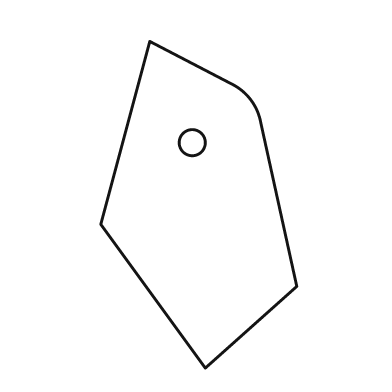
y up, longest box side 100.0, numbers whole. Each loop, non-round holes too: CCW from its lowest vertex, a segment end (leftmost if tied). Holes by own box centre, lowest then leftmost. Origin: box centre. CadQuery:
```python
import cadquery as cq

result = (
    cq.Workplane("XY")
    .moveTo(2.0, -50.0)
    .lineTo(30.0, -25.0)
    .lineTo(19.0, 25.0)
    .threePointArc((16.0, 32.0), (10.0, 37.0))
    .lineTo(-15.0, 50.0)
    .lineTo(-30.0, -6.0)
    .close()
    .moveTo(-2.0, 19.0)
    .circle(4.0)
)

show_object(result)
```